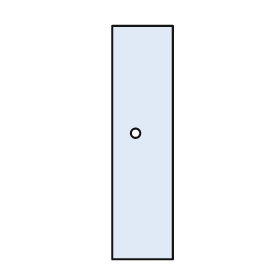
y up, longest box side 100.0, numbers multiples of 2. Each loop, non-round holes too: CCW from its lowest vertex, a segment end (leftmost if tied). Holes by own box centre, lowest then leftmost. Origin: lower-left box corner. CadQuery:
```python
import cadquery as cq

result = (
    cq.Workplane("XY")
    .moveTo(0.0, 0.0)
    .lineTo(26.0, 0.0)
    .lineTo(26.0, 100.0)
    .lineTo(0.0, 100.0)
    .close()
    .moveTo(10.0, 54.0)
    .circle(2.0)
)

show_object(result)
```